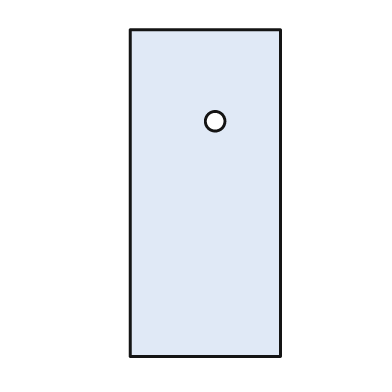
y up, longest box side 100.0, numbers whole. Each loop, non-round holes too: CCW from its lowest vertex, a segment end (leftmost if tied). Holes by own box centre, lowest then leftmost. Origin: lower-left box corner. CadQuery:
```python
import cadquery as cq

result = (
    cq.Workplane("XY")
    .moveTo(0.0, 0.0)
    .lineTo(46.0, 0.0)
    .lineTo(46.0, 100.0)
    .lineTo(0.0, 100.0)
    .close()
    .moveTo(26.0, 72.0)
    .circle(3.0)
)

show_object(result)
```